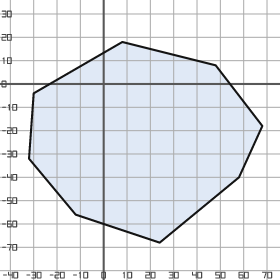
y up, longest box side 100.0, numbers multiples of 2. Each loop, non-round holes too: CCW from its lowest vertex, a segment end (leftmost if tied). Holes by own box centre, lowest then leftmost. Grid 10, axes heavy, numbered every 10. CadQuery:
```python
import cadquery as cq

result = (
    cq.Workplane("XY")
    .moveTo(24.0, -68.0)
    .lineTo(58.0, -40.0)
    .lineTo(68.0, -18.0)
    .lineTo(48.0, 8.0)
    .lineTo(8.0, 18.0)
    .lineTo(-30.0, -4.0)
    .lineTo(-32.0, -32.0)
    .lineTo(-12.0, -56.0)
    .close()
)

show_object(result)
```